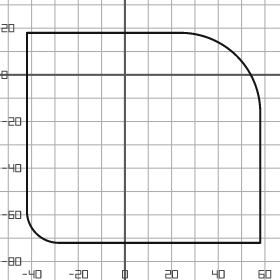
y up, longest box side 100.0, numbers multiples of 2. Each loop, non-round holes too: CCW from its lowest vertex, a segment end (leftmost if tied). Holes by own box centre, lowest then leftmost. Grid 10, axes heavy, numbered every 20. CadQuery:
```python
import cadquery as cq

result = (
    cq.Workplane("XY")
    .moveTo(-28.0, -72.0)
    .lineTo(58.0, -72.0)
    .lineTo(58.0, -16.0)
    .threePointArc((48.0, 8.0), (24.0, 18.0))
    .lineTo(-42.0, 18.0)
    .lineTo(-42.0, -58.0)
    .threePointArc((-38.0, -68.0), (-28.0, -72.0))
    .close()
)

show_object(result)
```